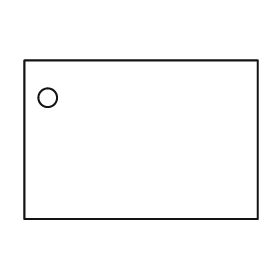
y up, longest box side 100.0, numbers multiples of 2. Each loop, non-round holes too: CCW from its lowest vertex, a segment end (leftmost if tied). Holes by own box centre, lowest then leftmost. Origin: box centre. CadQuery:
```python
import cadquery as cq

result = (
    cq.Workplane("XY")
    .moveTo(-50.0, -34.0)
    .lineTo(50.0, -34.0)
    .lineTo(50.0, 34.0)
    .lineTo(-50.0, 34.0)
    .close()
    .moveTo(-40.0, 18.0)
    .circle(4.0)
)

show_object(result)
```